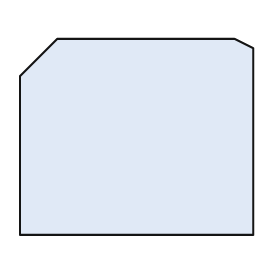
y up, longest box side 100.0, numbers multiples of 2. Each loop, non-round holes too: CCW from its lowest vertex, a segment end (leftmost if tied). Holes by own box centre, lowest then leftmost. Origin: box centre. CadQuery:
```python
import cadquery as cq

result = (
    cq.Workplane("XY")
    .moveTo(-50.0, -42.0)
    .lineTo(50.0, -42.0)
    .lineTo(50.0, 38.0)
    .lineTo(42.0, 42.0)
    .lineTo(-34.0, 42.0)
    .lineTo(-50.0, 26.0)
    .close()
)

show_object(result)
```